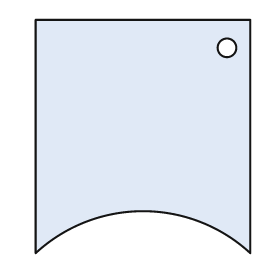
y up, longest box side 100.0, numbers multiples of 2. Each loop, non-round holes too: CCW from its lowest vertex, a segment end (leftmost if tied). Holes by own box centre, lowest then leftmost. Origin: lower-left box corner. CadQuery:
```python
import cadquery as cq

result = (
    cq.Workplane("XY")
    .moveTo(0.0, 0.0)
    .threePointArc((46.0, 18.0), (92.0, 0.0))
    .lineTo(92.0, 100.0)
    .lineTo(0.0, 100.0)
    .close()
    .moveTo(82.0, 88.0)
    .circle(4.0)
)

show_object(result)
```